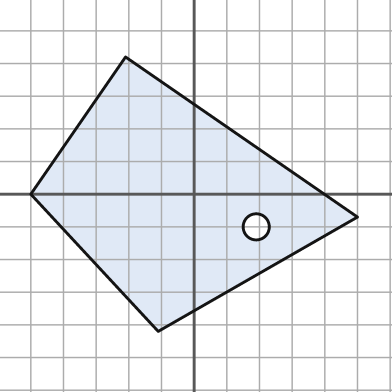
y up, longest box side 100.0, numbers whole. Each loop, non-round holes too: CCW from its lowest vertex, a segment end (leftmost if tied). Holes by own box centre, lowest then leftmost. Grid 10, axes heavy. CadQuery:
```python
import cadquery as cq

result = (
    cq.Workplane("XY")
    .moveTo(-11.0, -42.0)
    .lineTo(50.0, -7.0)
    .lineTo(-21.0, 42.0)
    .lineTo(-50.0, 0.0)
    .close()
    .moveTo(19.0, -10.0)
    .circle(4.0)
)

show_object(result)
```